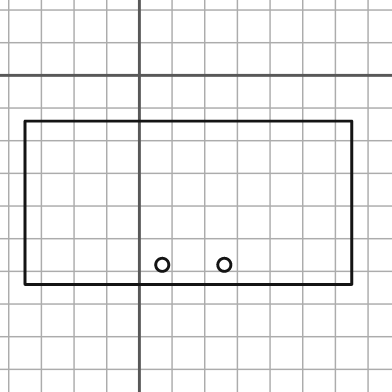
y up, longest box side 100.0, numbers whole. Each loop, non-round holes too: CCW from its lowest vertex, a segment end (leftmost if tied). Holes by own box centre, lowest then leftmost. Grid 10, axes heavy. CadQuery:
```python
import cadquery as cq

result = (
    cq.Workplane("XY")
    .moveTo(-35.0, -64.0)
    .lineTo(65.0, -64.0)
    .lineTo(65.0, -14.0)
    .lineTo(-35.0, -14.0)
    .close()
    .moveTo(7.0, -58.0)
    .circle(2.0)
    .moveTo(26.0, -58.0)
    .circle(2.0)
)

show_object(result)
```